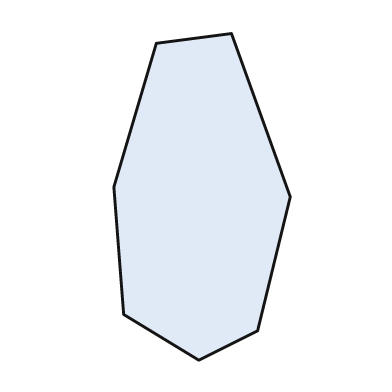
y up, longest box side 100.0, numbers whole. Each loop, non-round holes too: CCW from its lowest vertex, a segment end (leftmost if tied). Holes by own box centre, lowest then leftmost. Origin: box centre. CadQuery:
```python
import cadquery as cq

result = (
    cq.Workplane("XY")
    .moveTo(-1.0, -50.0)
    .lineTo(17.0, -41.0)
    .lineTo(27.0, 0.0)
    .lineTo(9.0, 50.0)
    .lineTo(-14.0, 47.0)
    .lineTo(-27.0, 3.0)
    .lineTo(-24.0, -36.0)
    .close()
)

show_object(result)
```